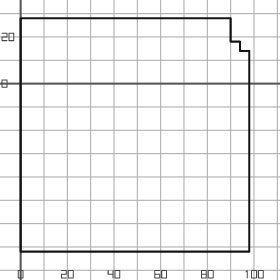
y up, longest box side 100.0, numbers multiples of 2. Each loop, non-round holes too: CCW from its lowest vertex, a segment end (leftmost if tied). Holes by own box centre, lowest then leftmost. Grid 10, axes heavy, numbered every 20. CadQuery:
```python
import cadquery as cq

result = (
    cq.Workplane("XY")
    .moveTo(0.0, -72.0)
    .lineTo(98.0, -72.0)
    .lineTo(98.0, 14.0)
    .lineTo(94.0, 14.0)
    .lineTo(94.0, 18.0)
    .lineTo(90.0, 18.0)
    .lineTo(90.0, 28.0)
    .lineTo(0.0, 28.0)
    .close()
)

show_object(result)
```